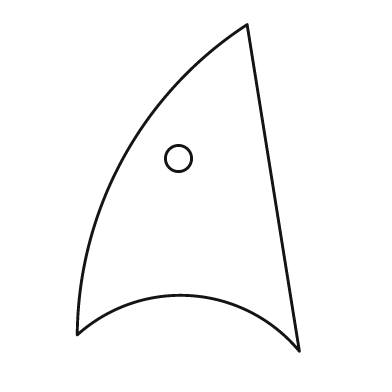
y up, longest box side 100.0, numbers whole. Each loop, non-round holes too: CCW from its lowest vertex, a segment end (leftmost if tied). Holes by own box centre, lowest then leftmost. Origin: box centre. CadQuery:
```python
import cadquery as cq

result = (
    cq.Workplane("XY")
    .moveTo(34.0, -50.0)
    .lineTo(18.0, 50.0)
    .threePointArc((-20.0, 9.0), (-34.0, -45.0))
    .threePointArc((1.0, -33.0), (34.0, -50.0))
    .close()
    .moveTo(-3.0, 9.0)
    .circle(4.0)
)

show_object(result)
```